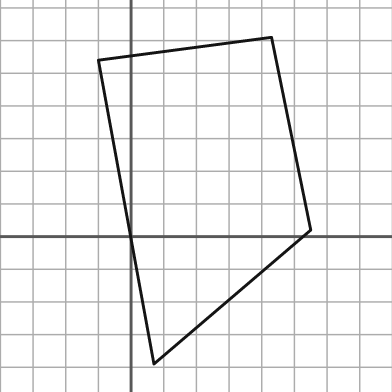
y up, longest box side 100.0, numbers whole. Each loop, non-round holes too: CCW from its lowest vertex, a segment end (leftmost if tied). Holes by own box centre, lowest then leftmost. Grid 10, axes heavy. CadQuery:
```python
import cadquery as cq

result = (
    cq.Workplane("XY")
    .moveTo(7.0, -39.0)
    .lineTo(55.0, 2.0)
    .lineTo(43.0, 61.0)
    .lineTo(-10.0, 54.0)
    .close()
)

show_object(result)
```